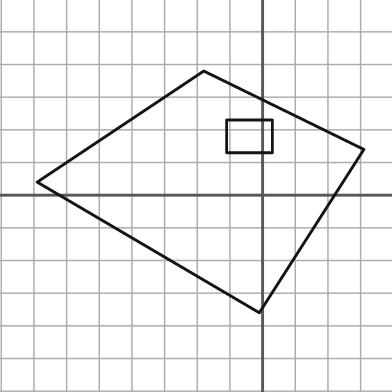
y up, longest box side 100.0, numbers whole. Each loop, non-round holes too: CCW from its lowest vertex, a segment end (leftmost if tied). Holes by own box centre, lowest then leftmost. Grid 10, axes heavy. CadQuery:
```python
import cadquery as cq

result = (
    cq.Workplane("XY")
    .moveTo(-1.0, -36.0)
    .lineTo(31.0, 14.0)
    .lineTo(-18.0, 38.0)
    .lineTo(-69.0, 4.0)
    .close()
    .moveTo(-11.0, 13.0)
    .lineTo(3.0, 13.0)
    .lineTo(3.0, 23.0)
    .lineTo(-11.0, 23.0)
    .close()
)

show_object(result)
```